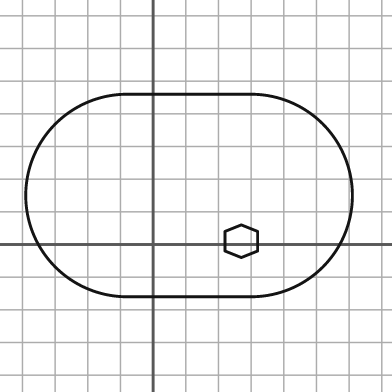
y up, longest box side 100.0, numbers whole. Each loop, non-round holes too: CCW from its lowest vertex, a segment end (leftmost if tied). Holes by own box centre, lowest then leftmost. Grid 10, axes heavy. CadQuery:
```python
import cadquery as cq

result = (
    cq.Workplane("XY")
    .moveTo(-8.0, -16.0)
    .lineTo(30.0, -16.0)
    .threePointArc((61.0, 15.0), (30.0, 46.0))
    .lineTo(-8.0, 46.0)
    .threePointArc((-39.0, 15.0), (-8.0, -16.0))
    .close()
    .moveTo(27.0, -4.0)
    .lineTo(32.0, -2.0)
    .lineTo(32.0, 4.0)
    .lineTo(27.0, 6.0)
    .lineTo(22.0, 4.0)
    .lineTo(22.0, -2.0)
    .close()
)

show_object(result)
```